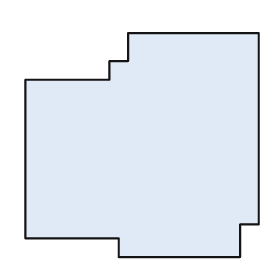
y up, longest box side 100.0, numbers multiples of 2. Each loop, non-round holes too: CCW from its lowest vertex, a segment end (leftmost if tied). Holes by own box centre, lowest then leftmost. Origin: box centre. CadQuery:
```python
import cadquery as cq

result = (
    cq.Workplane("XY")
    .moveTo(-10.0, -48.0)
    .lineTo(42.0, -48.0)
    .lineTo(42.0, -34.0)
    .lineTo(50.0, -34.0)
    .lineTo(50.0, 48.0)
    .lineTo(-6.0, 48.0)
    .lineTo(-6.0, 36.0)
    .lineTo(-14.0, 36.0)
    .lineTo(-14.0, 28.0)
    .lineTo(-50.0, 28.0)
    .lineTo(-50.0, -40.0)
    .lineTo(-10.0, -40.0)
    .close()
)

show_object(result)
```